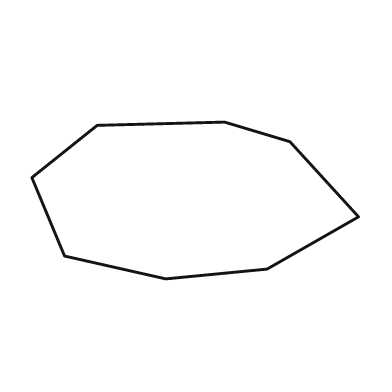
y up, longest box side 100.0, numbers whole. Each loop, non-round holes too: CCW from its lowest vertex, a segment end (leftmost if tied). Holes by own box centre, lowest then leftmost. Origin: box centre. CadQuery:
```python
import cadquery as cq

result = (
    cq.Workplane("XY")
    .moveTo(-9.0, -24.0)
    .lineTo(22.0, -21.0)
    .lineTo(50.0, -5.0)
    .lineTo(29.0, 18.0)
    .lineTo(9.0, 24.0)
    .lineTo(-30.0, 23.0)
    .lineTo(-50.0, 7.0)
    .lineTo(-40.0, -17.0)
    .close()
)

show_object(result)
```